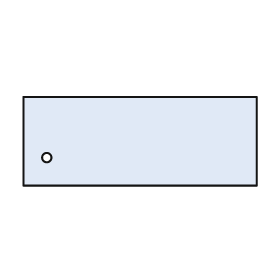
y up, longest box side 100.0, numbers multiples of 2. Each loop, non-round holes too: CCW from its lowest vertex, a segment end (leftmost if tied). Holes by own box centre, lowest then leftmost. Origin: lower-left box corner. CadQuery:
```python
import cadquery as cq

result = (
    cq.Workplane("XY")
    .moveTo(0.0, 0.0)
    .lineTo(100.0, 0.0)
    .lineTo(100.0, 38.0)
    .lineTo(0.0, 38.0)
    .close()
    .moveTo(10.0, 12.0)
    .circle(2.0)
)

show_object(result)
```